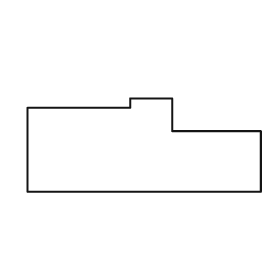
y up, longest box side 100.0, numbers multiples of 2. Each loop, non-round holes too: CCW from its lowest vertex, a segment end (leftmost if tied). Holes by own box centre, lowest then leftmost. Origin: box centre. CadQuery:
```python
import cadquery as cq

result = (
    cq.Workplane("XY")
    .moveTo(-50.0, -20.0)
    .lineTo(50.0, -20.0)
    .lineTo(50.0, 6.0)
    .lineTo(12.0, 6.0)
    .lineTo(12.0, 20.0)
    .lineTo(-6.0, 20.0)
    .lineTo(-6.0, 16.0)
    .lineTo(-50.0, 16.0)
    .close()
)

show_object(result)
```